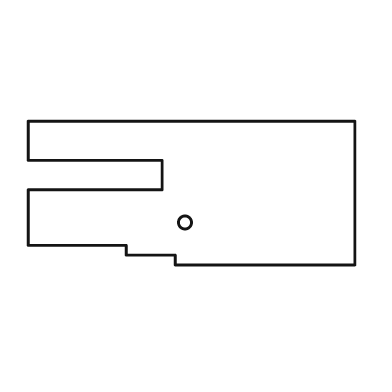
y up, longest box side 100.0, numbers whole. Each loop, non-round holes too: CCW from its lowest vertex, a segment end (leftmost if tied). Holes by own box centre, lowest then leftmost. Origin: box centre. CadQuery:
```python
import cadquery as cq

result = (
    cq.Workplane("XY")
    .moveTo(-5.0, -22.0)
    .lineTo(50.0, -22.0)
    .lineTo(50.0, 22.0)
    .lineTo(-50.0, 22.0)
    .lineTo(-50.0, 10.0)
    .lineTo(-9.0, 10.0)
    .lineTo(-9.0, 1.0)
    .lineTo(-50.0, 1.0)
    .lineTo(-50.0, -16.0)
    .lineTo(-20.0, -16.0)
    .lineTo(-20.0, -19.0)
    .lineTo(-5.0, -19.0)
    .close()
    .moveTo(-2.0, -9.0)
    .circle(2.0)
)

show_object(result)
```